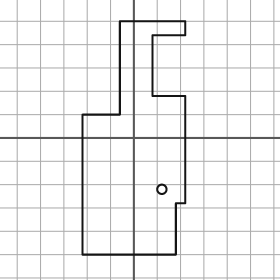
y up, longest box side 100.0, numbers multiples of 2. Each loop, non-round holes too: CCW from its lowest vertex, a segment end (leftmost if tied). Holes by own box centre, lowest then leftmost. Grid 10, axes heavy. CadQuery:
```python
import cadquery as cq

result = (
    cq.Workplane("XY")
    .moveTo(-22.0, -50.0)
    .lineTo(18.0, -50.0)
    .lineTo(18.0, -28.0)
    .lineTo(22.0, -28.0)
    .lineTo(22.0, 18.0)
    .lineTo(8.0, 18.0)
    .lineTo(8.0, 44.0)
    .lineTo(22.0, 44.0)
    .lineTo(22.0, 50.0)
    .lineTo(-6.0, 50.0)
    .lineTo(-6.0, 10.0)
    .lineTo(-22.0, 10.0)
    .close()
    .moveTo(12.0, -22.0)
    .circle(2.0)
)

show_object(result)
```